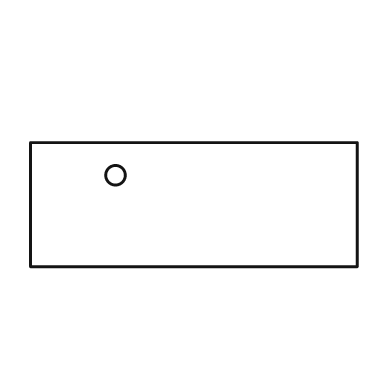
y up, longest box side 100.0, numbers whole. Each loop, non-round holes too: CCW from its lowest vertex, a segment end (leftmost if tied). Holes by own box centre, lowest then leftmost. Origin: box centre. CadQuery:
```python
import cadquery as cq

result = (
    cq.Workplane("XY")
    .moveTo(-50.0, -19.0)
    .lineTo(50.0, -19.0)
    .lineTo(50.0, 19.0)
    .lineTo(-50.0, 19.0)
    .close()
    .moveTo(-24.0, 9.0)
    .circle(3.0)
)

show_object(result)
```